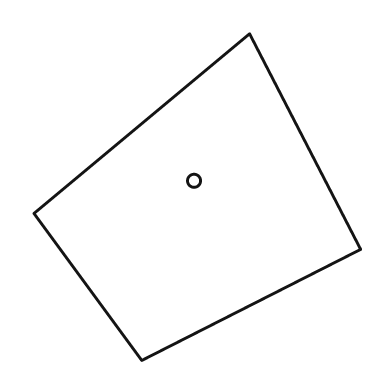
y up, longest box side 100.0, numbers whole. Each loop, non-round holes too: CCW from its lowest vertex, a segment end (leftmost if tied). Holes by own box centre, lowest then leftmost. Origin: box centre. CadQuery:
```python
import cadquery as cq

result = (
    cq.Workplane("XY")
    .moveTo(-17.0, -50.0)
    .lineTo(50.0, -16.0)
    .lineTo(16.0, 50.0)
    .lineTo(-50.0, -5.0)
    .close()
    .moveTo(-1.0, 5.0)
    .circle(2.0)
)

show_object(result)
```